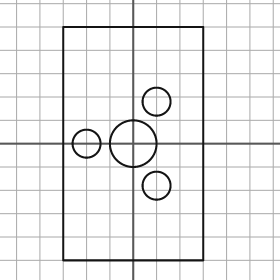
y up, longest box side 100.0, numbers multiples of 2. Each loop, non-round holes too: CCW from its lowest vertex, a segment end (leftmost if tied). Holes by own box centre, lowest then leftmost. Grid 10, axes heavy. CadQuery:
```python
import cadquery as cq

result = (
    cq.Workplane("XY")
    .moveTo(-30.0, -50.0)
    .lineTo(30.0, -50.0)
    .lineTo(30.0, 50.0)
    .lineTo(-30.0, 50.0)
    .close()
    .moveTo(10.0, -18.0)
    .circle(6.0)
    .moveTo(-20.0, 0.0)
    .circle(6.0)
    .moveTo(0.0, 0.0)
    .circle(10.0)
    .moveTo(10.0, 18.0)
    .circle(6.0)
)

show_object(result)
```